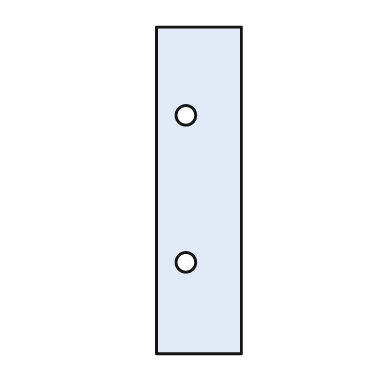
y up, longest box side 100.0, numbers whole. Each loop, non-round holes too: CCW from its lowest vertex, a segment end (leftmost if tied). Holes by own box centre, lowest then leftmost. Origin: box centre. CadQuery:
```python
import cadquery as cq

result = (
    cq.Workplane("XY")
    .moveTo(-13.0, -50.0)
    .lineTo(13.0, -50.0)
    .lineTo(13.0, 50.0)
    .lineTo(-13.0, 50.0)
    .close()
    .moveTo(-4.0, -22.0)
    .circle(3.0)
    .moveTo(-4.0, 23.0)
    .circle(3.0)
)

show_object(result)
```